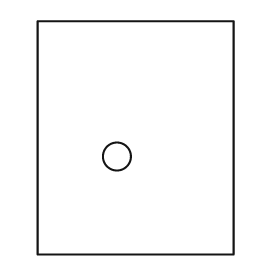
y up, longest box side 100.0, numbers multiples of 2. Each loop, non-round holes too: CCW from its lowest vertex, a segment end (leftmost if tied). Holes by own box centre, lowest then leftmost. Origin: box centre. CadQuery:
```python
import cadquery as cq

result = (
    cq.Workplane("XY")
    .moveTo(-42.0, -50.0)
    .lineTo(42.0, -50.0)
    .lineTo(42.0, 50.0)
    .lineTo(-42.0, 50.0)
    .close()
    .moveTo(-8.0, -8.0)
    .circle(6.0)
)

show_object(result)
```